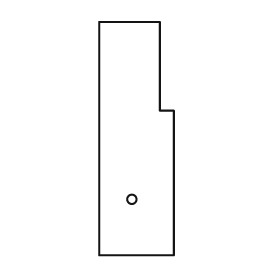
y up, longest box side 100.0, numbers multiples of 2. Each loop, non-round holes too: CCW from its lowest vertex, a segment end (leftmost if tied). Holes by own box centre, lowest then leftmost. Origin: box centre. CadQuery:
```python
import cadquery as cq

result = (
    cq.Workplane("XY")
    .moveTo(-16.0, -50.0)
    .lineTo(16.0, -50.0)
    .lineTo(16.0, 12.0)
    .lineTo(10.0, 12.0)
    .lineTo(10.0, 50.0)
    .lineTo(-16.0, 50.0)
    .close()
    .moveTo(-2.0, -26.0)
    .circle(2.0)
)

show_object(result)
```